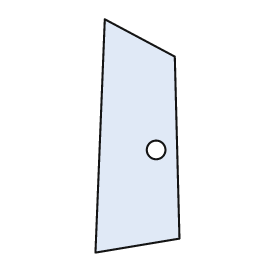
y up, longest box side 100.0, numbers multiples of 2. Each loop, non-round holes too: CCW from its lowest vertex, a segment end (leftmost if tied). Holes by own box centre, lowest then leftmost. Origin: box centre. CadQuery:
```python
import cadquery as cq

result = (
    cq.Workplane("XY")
    .moveTo(-18.0, -50.0)
    .lineTo(18.0, -44.0)
    .lineTo(16.0, 34.0)
    .lineTo(-14.0, 50.0)
    .close()
    .moveTo(8.0, -6.0)
    .circle(4.0)
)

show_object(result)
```